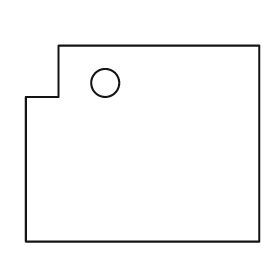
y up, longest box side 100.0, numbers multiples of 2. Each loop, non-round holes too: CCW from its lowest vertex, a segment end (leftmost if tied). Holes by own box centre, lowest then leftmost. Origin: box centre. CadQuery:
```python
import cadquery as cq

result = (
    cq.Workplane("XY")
    .moveTo(-50.0, -42.0)
    .lineTo(50.0, -42.0)
    .lineTo(50.0, 42.0)
    .lineTo(-36.0, 42.0)
    .lineTo(-36.0, 20.0)
    .lineTo(-50.0, 20.0)
    .close()
    .moveTo(-16.0, 26.0)
    .circle(6.0)
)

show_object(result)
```